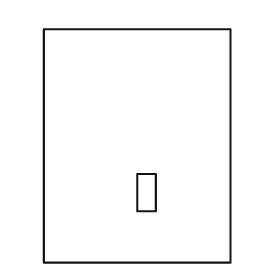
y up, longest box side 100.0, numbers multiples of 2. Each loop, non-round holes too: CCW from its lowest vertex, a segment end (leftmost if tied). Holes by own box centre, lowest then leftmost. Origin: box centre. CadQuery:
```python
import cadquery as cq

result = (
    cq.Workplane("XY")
    .moveTo(-40.0, -50.0)
    .lineTo(40.0, -50.0)
    .lineTo(40.0, 50.0)
    .lineTo(-40.0, 50.0)
    .close()
    .moveTo(0.0, -28.0)
    .lineTo(8.0, -28.0)
    .lineTo(8.0, -12.0)
    .lineTo(0.0, -12.0)
    .close()
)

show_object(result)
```